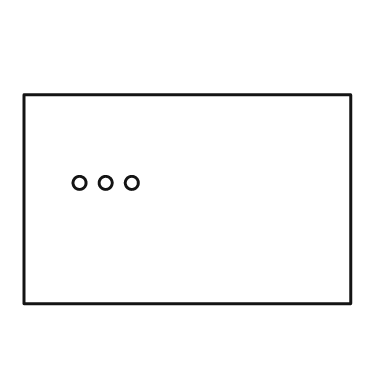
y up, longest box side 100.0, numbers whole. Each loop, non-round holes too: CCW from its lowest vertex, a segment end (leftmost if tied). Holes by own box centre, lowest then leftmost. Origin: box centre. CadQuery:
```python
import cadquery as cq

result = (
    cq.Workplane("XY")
    .moveTo(-50.0, -32.0)
    .lineTo(50.0, -32.0)
    .lineTo(50.0, 32.0)
    .lineTo(-50.0, 32.0)
    .close()
    .moveTo(-33.0, 5.0)
    .circle(2.0)
    .moveTo(-25.0, 5.0)
    .circle(2.0)
    .moveTo(-17.0, 5.0)
    .circle(2.0)
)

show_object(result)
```